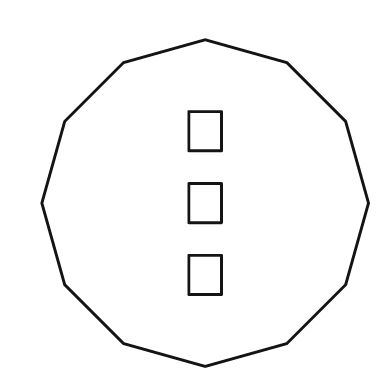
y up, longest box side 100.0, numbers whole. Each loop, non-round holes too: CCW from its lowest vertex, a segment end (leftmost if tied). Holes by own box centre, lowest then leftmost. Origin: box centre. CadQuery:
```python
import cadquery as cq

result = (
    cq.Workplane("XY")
    .moveTo(0.0, -50.0)
    .lineTo(25.0, -43.0)
    .lineTo(43.0, -25.0)
    .lineTo(50.0, 0.0)
    .lineTo(43.0, 25.0)
    .lineTo(25.0, 43.0)
    .lineTo(0.0, 50.0)
    .lineTo(-25.0, 43.0)
    .lineTo(-43.0, 25.0)
    .lineTo(-50.0, 0.0)
    .lineTo(-43.0, -25.0)
    .lineTo(-25.0, -43.0)
    .close()
    .moveTo(-5.0, -28.0)
    .lineTo(5.0, -28.0)
    .lineTo(5.0, -16.0)
    .lineTo(-5.0, -16.0)
    .close()
    .moveTo(-5.0, -6.0)
    .lineTo(5.0, -6.0)
    .lineTo(5.0, 6.0)
    .lineTo(-5.0, 6.0)
    .close()
    .moveTo(-5.0, 16.0)
    .lineTo(5.0, 16.0)
    .lineTo(5.0, 28.0)
    .lineTo(-5.0, 28.0)
    .close()
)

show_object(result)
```